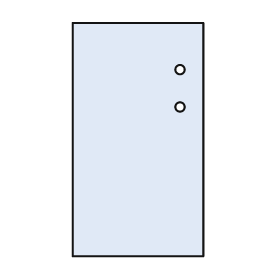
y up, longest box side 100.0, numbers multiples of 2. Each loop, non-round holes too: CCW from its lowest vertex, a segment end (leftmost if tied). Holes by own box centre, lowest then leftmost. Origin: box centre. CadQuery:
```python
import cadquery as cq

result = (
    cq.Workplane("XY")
    .moveTo(-28.0, -50.0)
    .lineTo(28.0, -50.0)
    .lineTo(28.0, 50.0)
    .lineTo(-28.0, 50.0)
    .close()
    .moveTo(18.0, 14.0)
    .circle(2.0)
    .moveTo(18.0, 30.0)
    .circle(2.0)
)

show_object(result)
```